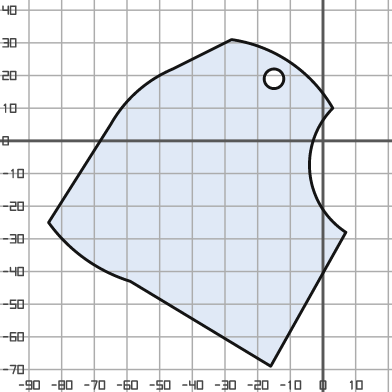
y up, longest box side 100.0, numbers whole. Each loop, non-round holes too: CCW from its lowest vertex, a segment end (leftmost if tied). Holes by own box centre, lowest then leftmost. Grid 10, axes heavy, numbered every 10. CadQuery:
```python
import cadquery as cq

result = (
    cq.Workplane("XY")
    .moveTo(-16.0, -69.0)
    .lineTo(7.0, -28.0)
    .threePointArc((-4.0, -10.0), (3.0, 10.0))
    .threePointArc((-10.0, 24.0), (-28.0, 31.0))
    .lineTo(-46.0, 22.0)
    .threePointArc((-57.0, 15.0), (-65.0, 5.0))
    .lineTo(-84.0, -25.0)
    .threePointArc((-73.0, -36.0), (-59.0, -43.0))
    .close()
    .moveTo(-15.0, 19.0)
    .circle(3.0)
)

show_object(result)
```